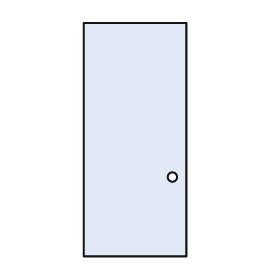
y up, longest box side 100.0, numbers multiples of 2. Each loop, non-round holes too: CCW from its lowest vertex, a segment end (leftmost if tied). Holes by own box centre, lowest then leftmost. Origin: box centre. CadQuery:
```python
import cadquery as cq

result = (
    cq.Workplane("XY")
    .moveTo(-22.0, -50.0)
    .lineTo(22.0, -50.0)
    .lineTo(22.0, 50.0)
    .lineTo(-22.0, 50.0)
    .close()
    .moveTo(16.0, -16.0)
    .circle(2.0)
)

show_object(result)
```